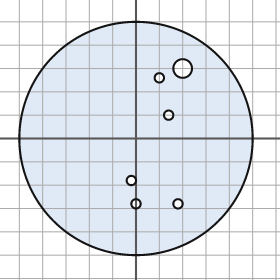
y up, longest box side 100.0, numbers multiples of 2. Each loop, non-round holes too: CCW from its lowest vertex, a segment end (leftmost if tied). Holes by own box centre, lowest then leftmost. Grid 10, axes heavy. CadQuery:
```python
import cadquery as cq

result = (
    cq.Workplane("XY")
    .moveTo(0.0, 0.0)
    .circle(50.0)
    .moveTo(0.0, -28.0)
    .circle(2.0)
    .moveTo(18.0, -28.0)
    .circle(2.0)
    .moveTo(-2.0, -18.0)
    .circle(2.0)
    .moveTo(14.0, 10.0)
    .circle(2.0)
    .moveTo(10.0, 26.0)
    .circle(2.0)
    .moveTo(20.0, 30.0)
    .circle(4.0)
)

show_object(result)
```